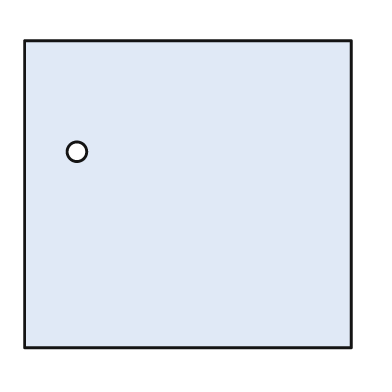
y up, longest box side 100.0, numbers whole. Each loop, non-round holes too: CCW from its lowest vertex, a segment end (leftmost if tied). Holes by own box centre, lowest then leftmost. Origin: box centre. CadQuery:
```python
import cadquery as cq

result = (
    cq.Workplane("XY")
    .moveTo(-50.0, -47.0)
    .lineTo(50.0, -47.0)
    .lineTo(50.0, 47.0)
    .lineTo(-50.0, 47.0)
    .close()
    .moveTo(-34.0, 13.0)
    .circle(3.0)
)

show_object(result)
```